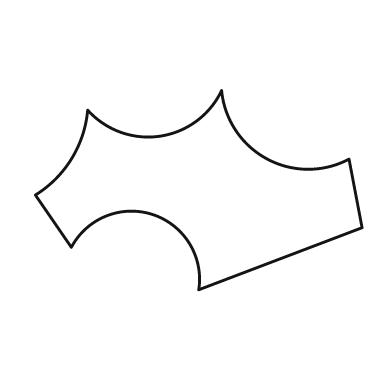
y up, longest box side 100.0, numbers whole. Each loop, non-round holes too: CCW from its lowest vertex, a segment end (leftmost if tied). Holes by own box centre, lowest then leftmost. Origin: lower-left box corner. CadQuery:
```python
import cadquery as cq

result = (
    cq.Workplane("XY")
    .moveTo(50.0, 0.0)
    .lineTo(100.0, 19.0)
    .lineTo(96.0, 40.0)
    .threePointArc((71.0, 40.0), (57.0, 61.0))
    .threePointArc((38.0, 47.0), (16.0, 55.0))
    .threePointArc((11.0, 40.0), (0.0, 29.0))
    .lineTo(11.0, 13.0)
    .threePointArc((36.0, 23.0), (50.0, 0.0))
    .close()
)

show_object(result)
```